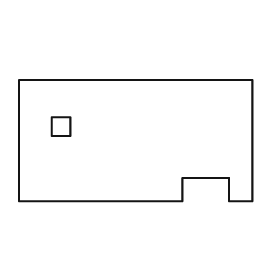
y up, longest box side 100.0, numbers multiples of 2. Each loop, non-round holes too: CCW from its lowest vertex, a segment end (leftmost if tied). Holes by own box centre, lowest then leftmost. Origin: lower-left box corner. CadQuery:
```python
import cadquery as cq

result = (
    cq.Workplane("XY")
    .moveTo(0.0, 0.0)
    .lineTo(70.0, 0.0)
    .lineTo(70.0, 10.0)
    .lineTo(90.0, 10.0)
    .lineTo(90.0, 0.0)
    .lineTo(100.0, 0.0)
    .lineTo(100.0, 52.0)
    .lineTo(0.0, 52.0)
    .close()
    .moveTo(14.0, 28.0)
    .lineTo(22.0, 28.0)
    .lineTo(22.0, 36.0)
    .lineTo(14.0, 36.0)
    .close()
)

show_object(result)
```